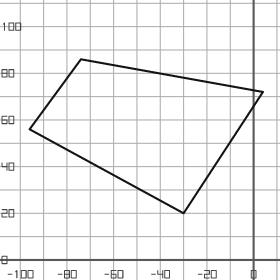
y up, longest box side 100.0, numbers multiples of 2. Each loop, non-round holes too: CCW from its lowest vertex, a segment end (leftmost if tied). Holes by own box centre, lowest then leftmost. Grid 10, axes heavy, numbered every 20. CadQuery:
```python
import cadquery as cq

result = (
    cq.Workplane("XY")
    .moveTo(-30.0, 20.0)
    .lineTo(4.0, 72.0)
    .lineTo(-74.0, 86.0)
    .lineTo(-96.0, 56.0)
    .close()
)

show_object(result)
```